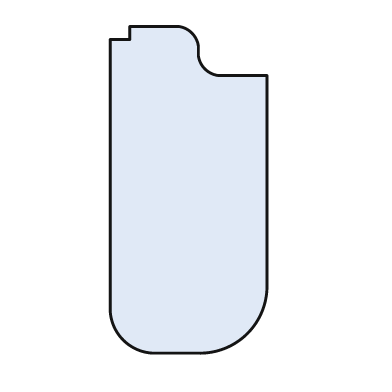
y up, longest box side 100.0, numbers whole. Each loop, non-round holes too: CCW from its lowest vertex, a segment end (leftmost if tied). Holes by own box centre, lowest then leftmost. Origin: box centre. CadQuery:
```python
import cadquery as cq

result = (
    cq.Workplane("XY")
    .moveTo(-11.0, -50.0)
    .lineTo(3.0, -50.0)
    .threePointArc((18.0, -44.0), (24.0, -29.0))
    .lineTo(24.0, 35.0)
    .lineTo(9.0, 35.0)
    .threePointArc((5.0, 37.0), (3.0, 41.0))
    .lineTo(3.0, 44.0)
    .threePointArc((1.0, 48.0), (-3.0, 50.0))
    .lineTo(-18.0, 50.0)
    .lineTo(-18.0, 46.0)
    .lineTo(-24.0, 46.0)
    .lineTo(-24.0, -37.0)
    .threePointArc((-20.0, -46.0), (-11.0, -50.0))
    .close()
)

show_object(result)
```